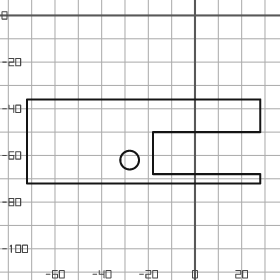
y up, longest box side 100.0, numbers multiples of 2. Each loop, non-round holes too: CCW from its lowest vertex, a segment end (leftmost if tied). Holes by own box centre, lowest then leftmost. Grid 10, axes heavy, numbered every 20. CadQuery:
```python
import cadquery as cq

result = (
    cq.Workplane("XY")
    .moveTo(-72.0, -72.0)
    .lineTo(28.0, -72.0)
    .lineTo(28.0, -68.0)
    .lineTo(-18.0, -68.0)
    .lineTo(-18.0, -50.0)
    .lineTo(28.0, -50.0)
    .lineTo(28.0, -36.0)
    .lineTo(-72.0, -36.0)
    .close()
    .moveTo(-28.0, -62.0)
    .circle(4.0)
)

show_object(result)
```